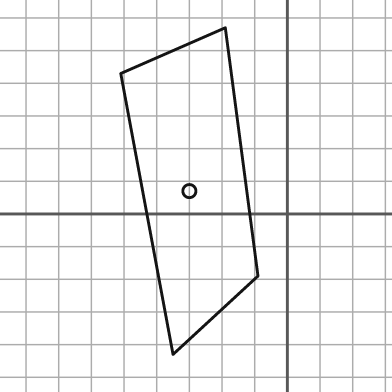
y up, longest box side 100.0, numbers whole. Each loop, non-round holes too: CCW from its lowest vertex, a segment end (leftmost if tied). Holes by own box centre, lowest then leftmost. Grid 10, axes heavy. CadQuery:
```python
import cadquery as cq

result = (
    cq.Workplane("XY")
    .moveTo(-35.0, -43.0)
    .lineTo(-9.0, -19.0)
    .lineTo(-19.0, 57.0)
    .lineTo(-51.0, 43.0)
    .close()
    .moveTo(-30.0, 7.0)
    .circle(2.0)
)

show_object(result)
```